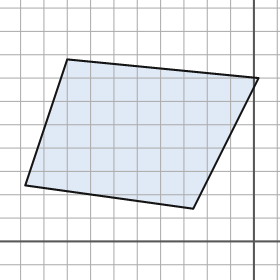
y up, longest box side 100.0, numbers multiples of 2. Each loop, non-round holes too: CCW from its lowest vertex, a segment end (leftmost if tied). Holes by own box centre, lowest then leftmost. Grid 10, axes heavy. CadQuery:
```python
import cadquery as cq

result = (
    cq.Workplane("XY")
    .moveTo(-26.0, 14.0)
    .lineTo(2.0, 70.0)
    .lineTo(-80.0, 78.0)
    .lineTo(-98.0, 24.0)
    .close()
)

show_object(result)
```